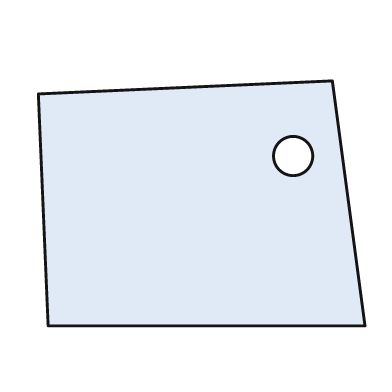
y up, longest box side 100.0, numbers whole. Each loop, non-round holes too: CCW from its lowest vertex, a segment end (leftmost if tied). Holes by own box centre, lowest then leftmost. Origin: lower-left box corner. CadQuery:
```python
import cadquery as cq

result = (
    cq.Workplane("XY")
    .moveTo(3.0, 0.0)
    .lineTo(100.0, 0.0)
    .lineTo(90.0, 75.0)
    .lineTo(0.0, 71.0)
    .close()
    .moveTo(78.0, 52.0)
    .circle(6.0)
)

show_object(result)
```